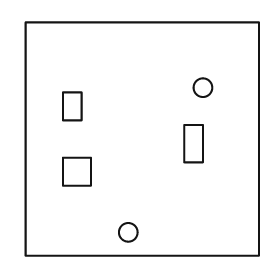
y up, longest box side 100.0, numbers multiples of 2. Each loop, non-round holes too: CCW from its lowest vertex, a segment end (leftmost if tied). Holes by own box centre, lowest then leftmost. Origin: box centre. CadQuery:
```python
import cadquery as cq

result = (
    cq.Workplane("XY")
    .moveTo(-50.0, -50.0)
    .lineTo(50.0, -50.0)
    .lineTo(50.0, 50.0)
    .lineTo(-50.0, 50.0)
    .close()
    .moveTo(-6.0, -40.0)
    .circle(4.0)
    .moveTo(-34.0, -20.0)
    .lineTo(-22.0, -20.0)
    .lineTo(-22.0, -8.0)
    .lineTo(-34.0, -8.0)
    .close()
    .moveTo(18.0, -10.0)
    .lineTo(26.0, -10.0)
    .lineTo(26.0, 6.0)
    .lineTo(18.0, 6.0)
    .close()
    .moveTo(-34.0, 8.0)
    .lineTo(-26.0, 8.0)
    .lineTo(-26.0, 20.0)
    .lineTo(-34.0, 20.0)
    .close()
    .moveTo(26.0, 22.0)
    .circle(4.0)
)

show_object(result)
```